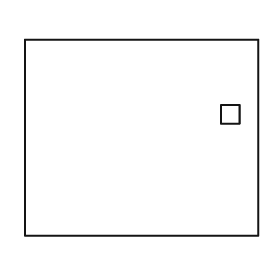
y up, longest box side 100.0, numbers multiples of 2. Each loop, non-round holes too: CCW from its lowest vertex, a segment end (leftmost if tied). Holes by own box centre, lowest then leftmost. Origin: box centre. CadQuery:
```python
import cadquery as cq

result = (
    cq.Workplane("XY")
    .moveTo(-50.0, -42.0)
    .lineTo(50.0, -42.0)
    .lineTo(50.0, 42.0)
    .lineTo(-50.0, 42.0)
    .close()
    .moveTo(34.0, 6.0)
    .lineTo(42.0, 6.0)
    .lineTo(42.0, 14.0)
    .lineTo(34.0, 14.0)
    .close()
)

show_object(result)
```